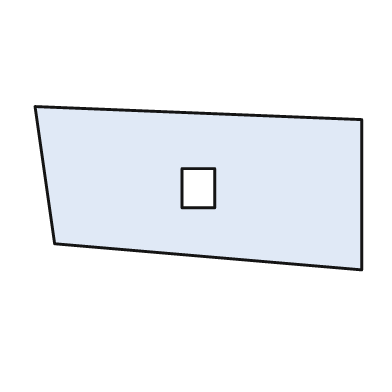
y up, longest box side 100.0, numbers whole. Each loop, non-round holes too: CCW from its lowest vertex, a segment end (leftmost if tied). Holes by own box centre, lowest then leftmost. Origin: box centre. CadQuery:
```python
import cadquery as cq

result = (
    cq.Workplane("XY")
    .moveTo(50.0, -25.0)
    .lineTo(50.0, 21.0)
    .lineTo(-50.0, 25.0)
    .lineTo(-44.0, -17.0)
    .close()
    .moveTo(-5.0, -6.0)
    .lineTo(5.0, -6.0)
    .lineTo(5.0, 6.0)
    .lineTo(-5.0, 6.0)
    .close()
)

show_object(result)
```